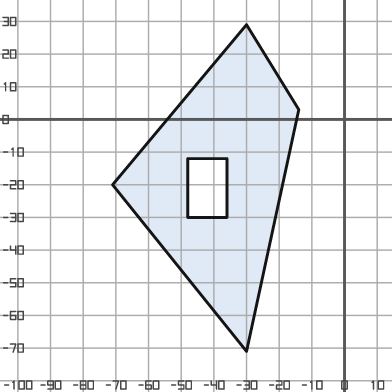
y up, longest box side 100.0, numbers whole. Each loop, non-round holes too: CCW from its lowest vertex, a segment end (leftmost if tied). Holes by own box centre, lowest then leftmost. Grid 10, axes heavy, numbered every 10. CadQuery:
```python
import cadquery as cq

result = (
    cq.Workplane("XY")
    .moveTo(-30.0, -71.0)
    .lineTo(-14.0, 3.0)
    .lineTo(-30.0, 29.0)
    .lineTo(-71.0, -20.0)
    .close()
    .moveTo(-48.0, -30.0)
    .lineTo(-36.0, -30.0)
    .lineTo(-36.0, -12.0)
    .lineTo(-48.0, -12.0)
    .close()
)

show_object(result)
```